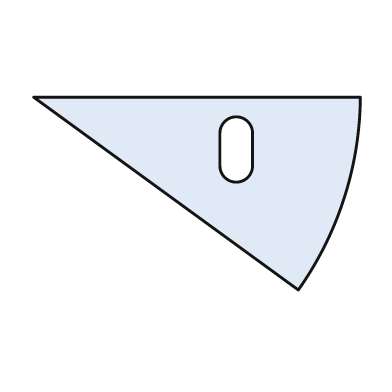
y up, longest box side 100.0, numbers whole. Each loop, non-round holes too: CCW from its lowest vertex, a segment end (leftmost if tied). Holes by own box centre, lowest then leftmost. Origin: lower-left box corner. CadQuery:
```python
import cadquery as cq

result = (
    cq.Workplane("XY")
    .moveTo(81.0, 0.0)
    .threePointArc((95.0, 28.0), (100.0, 59.0))
    .lineTo(0.0, 59.0)
    .close()
    .moveTo(57.0, 38.0)
    .threePointArc((62.0, 33.0), (67.0, 38.0))
    .lineTo(67.0, 48.0)
    .threePointArc((62.0, 53.0), (57.0, 48.0))
    .close()
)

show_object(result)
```